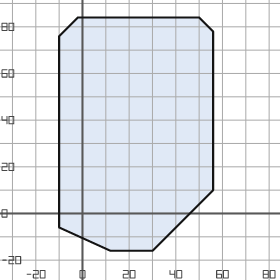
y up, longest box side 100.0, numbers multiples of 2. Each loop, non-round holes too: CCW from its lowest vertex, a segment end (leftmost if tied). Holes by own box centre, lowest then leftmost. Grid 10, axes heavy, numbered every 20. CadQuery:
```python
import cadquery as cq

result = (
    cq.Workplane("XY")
    .moveTo(12.0, -16.0)
    .lineTo(30.0, -16.0)
    .lineTo(56.0, 10.0)
    .lineTo(56.0, 78.0)
    .lineTo(50.0, 84.0)
    .lineTo(-2.0, 84.0)
    .lineTo(-10.0, 76.0)
    .lineTo(-10.0, -6.0)
    .close()
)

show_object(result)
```